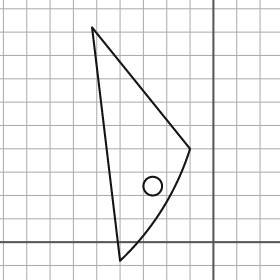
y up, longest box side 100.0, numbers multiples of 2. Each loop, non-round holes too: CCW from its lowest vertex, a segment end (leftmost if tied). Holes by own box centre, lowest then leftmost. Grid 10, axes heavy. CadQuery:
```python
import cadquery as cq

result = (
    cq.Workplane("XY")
    .moveTo(-40.0, -8.0)
    .threePointArc((-22.0, 14.0), (-10.0, 40.0))
    .lineTo(-52.0, 92.0)
    .close()
    .moveTo(-26.0, 24.0)
    .circle(4.0)
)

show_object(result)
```